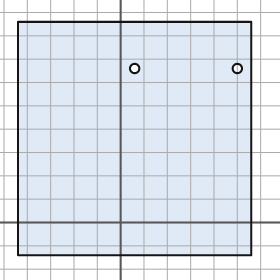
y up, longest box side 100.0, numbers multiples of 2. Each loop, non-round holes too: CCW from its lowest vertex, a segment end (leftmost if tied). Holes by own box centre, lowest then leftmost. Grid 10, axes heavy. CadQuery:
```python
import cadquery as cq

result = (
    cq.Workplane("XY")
    .moveTo(-44.0, -14.0)
    .lineTo(56.0, -14.0)
    .lineTo(56.0, 86.0)
    .lineTo(-44.0, 86.0)
    .close()
    .moveTo(6.0, 66.0)
    .circle(2.0)
    .moveTo(50.0, 66.0)
    .circle(2.0)
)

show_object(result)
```